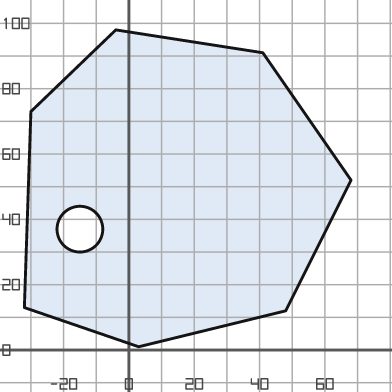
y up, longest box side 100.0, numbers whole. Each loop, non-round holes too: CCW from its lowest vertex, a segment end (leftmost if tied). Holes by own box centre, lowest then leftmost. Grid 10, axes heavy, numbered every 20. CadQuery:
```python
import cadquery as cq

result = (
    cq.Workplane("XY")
    .moveTo(3.0, 1.0)
    .lineTo(48.0, 12.0)
    .lineTo(68.0, 52.0)
    .lineTo(41.0, 91.0)
    .lineTo(-4.0, 98.0)
    .lineTo(-30.0, 73.0)
    .lineTo(-32.0, 13.0)
    .close()
    .moveTo(-15.0, 37.0)
    .circle(7.0)
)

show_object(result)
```